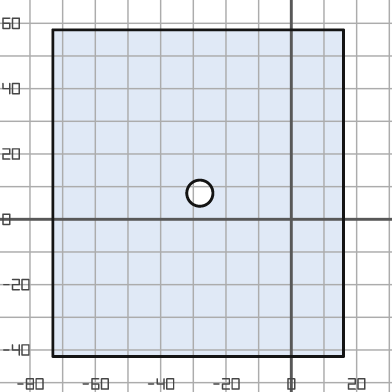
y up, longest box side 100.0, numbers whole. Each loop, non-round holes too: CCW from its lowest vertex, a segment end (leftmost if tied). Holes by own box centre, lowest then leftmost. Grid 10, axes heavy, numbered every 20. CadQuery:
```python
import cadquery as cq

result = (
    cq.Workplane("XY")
    .moveTo(-73.0, -42.0)
    .lineTo(16.0, -42.0)
    .lineTo(16.0, 58.0)
    .lineTo(-73.0, 58.0)
    .close()
    .moveTo(-28.0, 8.0)
    .circle(4.0)
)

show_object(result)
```